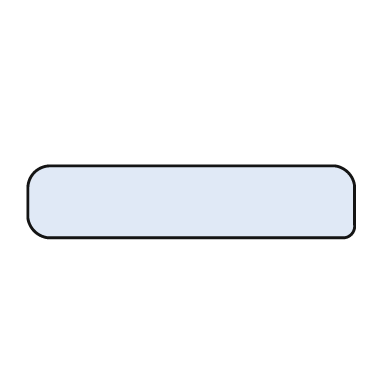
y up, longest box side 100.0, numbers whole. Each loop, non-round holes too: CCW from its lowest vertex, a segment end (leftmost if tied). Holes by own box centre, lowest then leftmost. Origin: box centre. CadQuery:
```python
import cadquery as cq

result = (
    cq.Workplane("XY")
    .moveTo(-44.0, -11.0)
    .lineTo(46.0, -11.0)
    .threePointArc((49.0, -10.0), (50.0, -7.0))
    .lineTo(50.0, 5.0)
    .threePointArc((48.0, 9.0), (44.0, 11.0))
    .lineTo(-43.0, 11.0)
    .threePointArc((-48.0, 9.0), (-50.0, 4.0))
    .lineTo(-50.0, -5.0)
    .threePointArc((-48.0, -9.0), (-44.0, -11.0))
    .close()
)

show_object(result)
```